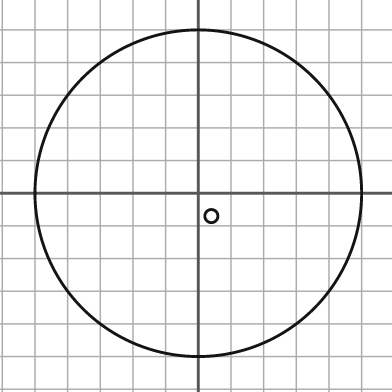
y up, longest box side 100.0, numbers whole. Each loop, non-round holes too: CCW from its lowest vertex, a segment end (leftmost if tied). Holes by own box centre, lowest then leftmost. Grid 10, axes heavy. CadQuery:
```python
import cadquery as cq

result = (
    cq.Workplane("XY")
    .moveTo(0.0, 0.0)
    .circle(50.0)
    .moveTo(4.0, -7.0)
    .circle(2.0)
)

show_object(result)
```